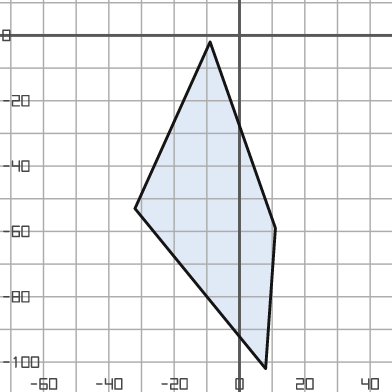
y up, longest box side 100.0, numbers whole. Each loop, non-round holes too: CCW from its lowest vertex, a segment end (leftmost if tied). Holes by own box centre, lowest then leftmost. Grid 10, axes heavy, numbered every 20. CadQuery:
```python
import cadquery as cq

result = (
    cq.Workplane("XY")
    .moveTo(8.0, -102.0)
    .lineTo(11.0, -59.0)
    .lineTo(-9.0, -2.0)
    .lineTo(-32.0, -53.0)
    .close()
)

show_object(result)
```